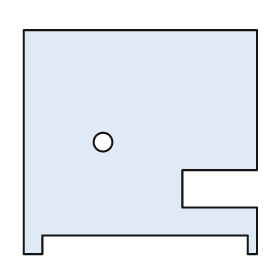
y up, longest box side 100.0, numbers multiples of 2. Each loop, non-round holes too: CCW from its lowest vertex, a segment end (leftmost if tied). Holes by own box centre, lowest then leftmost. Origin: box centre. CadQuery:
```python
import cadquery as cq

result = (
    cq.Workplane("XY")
    .moveTo(-50.0, -48.0)
    .lineTo(-42.0, -48.0)
    .lineTo(-42.0, -40.0)
    .lineTo(46.0, -40.0)
    .lineTo(46.0, -48.0)
    .lineTo(50.0, -48.0)
    .lineTo(50.0, -28.0)
    .lineTo(18.0, -28.0)
    .lineTo(18.0, -12.0)
    .lineTo(50.0, -12.0)
    .lineTo(50.0, 48.0)
    .lineTo(-50.0, 48.0)
    .close()
    .moveTo(-16.0, 0.0)
    .circle(4.0)
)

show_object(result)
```